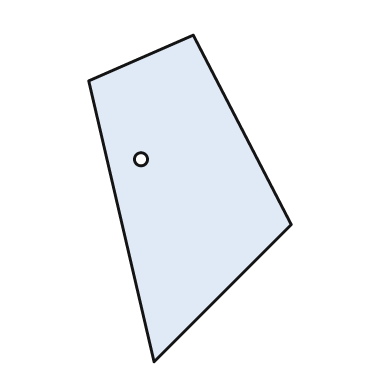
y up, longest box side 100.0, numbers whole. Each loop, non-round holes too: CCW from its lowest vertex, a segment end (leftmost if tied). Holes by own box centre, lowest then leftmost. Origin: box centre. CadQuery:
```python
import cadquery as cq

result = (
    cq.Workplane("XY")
    .moveTo(-11.0, -50.0)
    .lineTo(31.0, -8.0)
    .lineTo(1.0, 50.0)
    .lineTo(-31.0, 36.0)
    .close()
    .moveTo(-15.0, 12.0)
    .circle(2.0)
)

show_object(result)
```